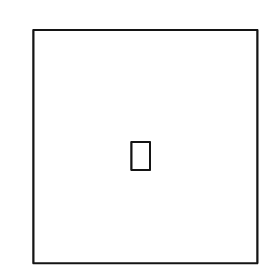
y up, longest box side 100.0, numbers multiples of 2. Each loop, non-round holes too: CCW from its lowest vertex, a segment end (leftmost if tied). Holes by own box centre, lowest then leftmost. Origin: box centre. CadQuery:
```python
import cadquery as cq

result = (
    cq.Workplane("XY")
    .moveTo(-48.0, -50.0)
    .lineTo(48.0, -50.0)
    .lineTo(48.0, 50.0)
    .lineTo(-48.0, 50.0)
    .close()
    .moveTo(-6.0, -10.0)
    .lineTo(2.0, -10.0)
    .lineTo(2.0, 2.0)
    .lineTo(-6.0, 2.0)
    .close()
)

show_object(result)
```